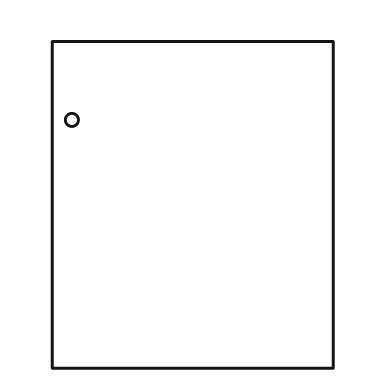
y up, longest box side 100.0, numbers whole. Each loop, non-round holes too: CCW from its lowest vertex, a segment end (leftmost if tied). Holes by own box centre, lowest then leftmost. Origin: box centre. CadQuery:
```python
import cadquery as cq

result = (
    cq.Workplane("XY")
    .moveTo(-43.0, -50.0)
    .lineTo(43.0, -50.0)
    .lineTo(43.0, 50.0)
    .lineTo(-43.0, 50.0)
    .close()
    .moveTo(-37.0, 26.0)
    .circle(2.0)
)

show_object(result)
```